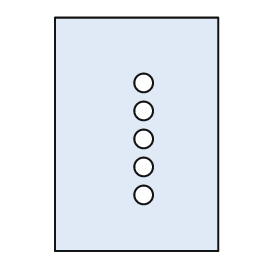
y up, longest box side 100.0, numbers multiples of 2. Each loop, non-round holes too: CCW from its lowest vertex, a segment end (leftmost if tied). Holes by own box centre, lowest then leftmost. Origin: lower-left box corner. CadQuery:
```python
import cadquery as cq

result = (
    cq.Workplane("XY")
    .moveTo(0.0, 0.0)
    .lineTo(70.0, 0.0)
    .lineTo(70.0, 100.0)
    .lineTo(0.0, 100.0)
    .close()
    .moveTo(38.0, 24.0)
    .circle(4.0)
    .moveTo(38.0, 36.0)
    .circle(4.0)
    .moveTo(38.0, 48.0)
    .circle(4.0)
    .moveTo(38.0, 60.0)
    .circle(4.0)
    .moveTo(38.0, 72.0)
    .circle(4.0)
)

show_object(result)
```